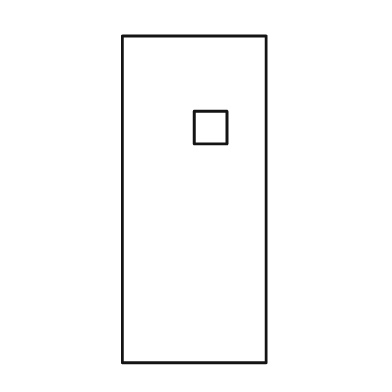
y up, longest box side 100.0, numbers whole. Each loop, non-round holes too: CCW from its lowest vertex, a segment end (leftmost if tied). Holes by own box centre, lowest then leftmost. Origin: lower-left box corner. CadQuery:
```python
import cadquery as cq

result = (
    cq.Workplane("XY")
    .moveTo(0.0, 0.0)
    .lineTo(44.0, 0.0)
    .lineTo(44.0, 100.0)
    .lineTo(0.0, 100.0)
    .close()
    .moveTo(22.0, 67.0)
    .lineTo(32.0, 67.0)
    .lineTo(32.0, 77.0)
    .lineTo(22.0, 77.0)
    .close()
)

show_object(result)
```